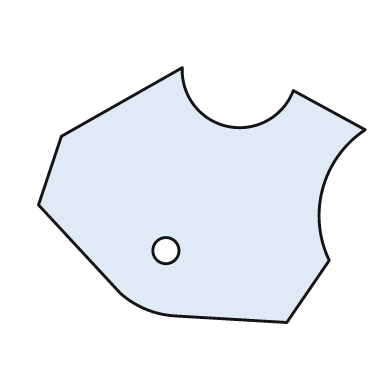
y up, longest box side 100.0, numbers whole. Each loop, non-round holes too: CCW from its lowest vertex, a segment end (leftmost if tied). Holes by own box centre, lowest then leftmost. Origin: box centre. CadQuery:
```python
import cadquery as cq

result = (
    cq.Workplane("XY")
    .moveTo(26.0, -39.0)
    .lineTo(39.0, -20.0)
    .threePointArc((37.0, 2.0), (50.0, 20.0))
    .lineTo(28.0, 32.0)
    .threePointArc((8.0, 21.0), (-6.0, 39.0))
    .lineTo(-43.0, 18.0)
    .lineTo(-50.0, -3.0)
    .lineTo(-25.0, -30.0)
    .threePointArc((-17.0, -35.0), (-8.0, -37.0))
    .close()
    .moveTo(-11.0, -17.0)
    .circle(4.0)
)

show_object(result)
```